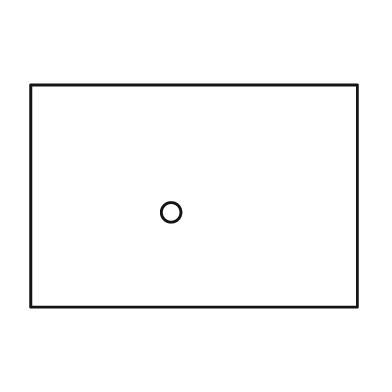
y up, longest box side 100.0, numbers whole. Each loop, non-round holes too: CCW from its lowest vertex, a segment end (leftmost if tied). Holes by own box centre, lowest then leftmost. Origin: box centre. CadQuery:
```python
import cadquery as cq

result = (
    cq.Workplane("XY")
    .moveTo(-50.0, -34.0)
    .lineTo(50.0, -34.0)
    .lineTo(50.0, 34.0)
    .lineTo(-50.0, 34.0)
    .close()
    .moveTo(-7.0, -5.0)
    .circle(3.0)
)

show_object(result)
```